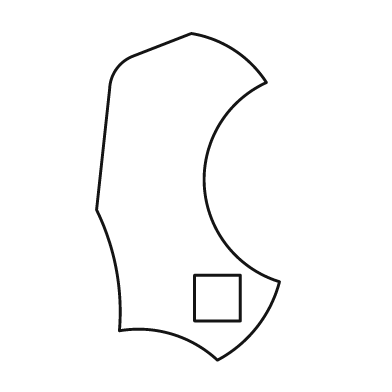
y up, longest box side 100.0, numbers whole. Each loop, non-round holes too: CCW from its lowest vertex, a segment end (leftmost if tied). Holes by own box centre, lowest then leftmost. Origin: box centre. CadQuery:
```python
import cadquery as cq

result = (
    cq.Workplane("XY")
    .moveTo(9.0, -50.0)
    .threePointArc((21.0, -40.0), (28.0, -26.0))
    .threePointArc((5.0, 3.0), (24.0, 35.0))
    .threePointArc((14.0, 45.0), (1.0, 50.0))
    .lineTo(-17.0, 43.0)
    .threePointArc((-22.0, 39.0), (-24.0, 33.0))
    .lineTo(-28.0, -4.0)
    .threePointArc((-22.0, -22.0), (-21.0, -41.0))
    .threePointArc((-5.0, -42.0), (9.0, -50.0))
    .close()
    .moveTo(2.0, -38.0)
    .lineTo(16.0, -38.0)
    .lineTo(16.0, -24.0)
    .lineTo(2.0, -24.0)
    .close()
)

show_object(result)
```